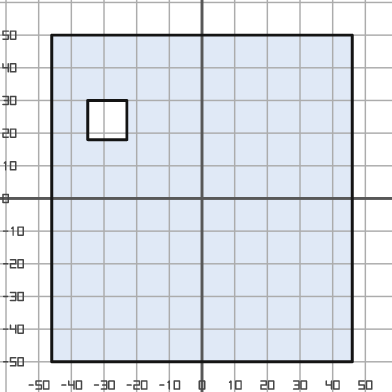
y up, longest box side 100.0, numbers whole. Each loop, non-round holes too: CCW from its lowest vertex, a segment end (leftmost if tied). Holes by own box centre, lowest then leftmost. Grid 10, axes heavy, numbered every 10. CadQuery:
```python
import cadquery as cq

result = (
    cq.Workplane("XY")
    .moveTo(-46.0, -50.0)
    .lineTo(46.0, -50.0)
    .lineTo(46.0, 50.0)
    .lineTo(-46.0, 50.0)
    .close()
    .moveTo(-35.0, 18.0)
    .lineTo(-23.0, 18.0)
    .lineTo(-23.0, 30.0)
    .lineTo(-35.0, 30.0)
    .close()
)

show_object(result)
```